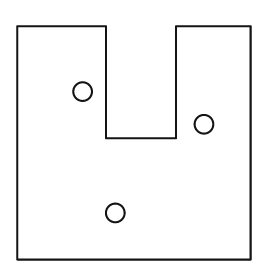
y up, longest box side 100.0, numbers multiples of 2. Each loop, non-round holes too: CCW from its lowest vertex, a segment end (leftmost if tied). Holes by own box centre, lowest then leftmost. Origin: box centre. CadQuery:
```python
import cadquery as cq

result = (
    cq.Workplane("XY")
    .moveTo(-50.0, -50.0)
    .lineTo(50.0, -50.0)
    .lineTo(50.0, 50.0)
    .lineTo(18.0, 50.0)
    .lineTo(18.0, 2.0)
    .lineTo(-12.0, 2.0)
    .lineTo(-12.0, 50.0)
    .lineTo(-50.0, 50.0)
    .close()
    .moveTo(-8.0, -30.0)
    .circle(4.0)
    .moveTo(30.0, 8.0)
    .circle(4.0)
    .moveTo(-22.0, 22.0)
    .circle(4.0)
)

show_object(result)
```